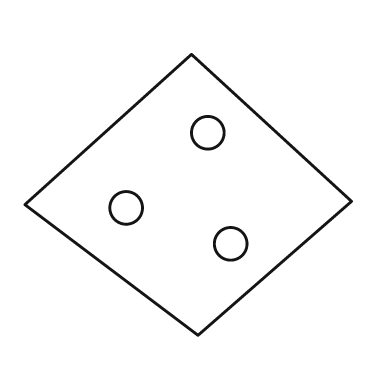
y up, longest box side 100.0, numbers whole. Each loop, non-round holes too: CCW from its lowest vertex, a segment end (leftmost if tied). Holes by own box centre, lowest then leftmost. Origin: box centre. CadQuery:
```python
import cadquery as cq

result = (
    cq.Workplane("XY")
    .moveTo(3.0, -43.0)
    .lineTo(50.0, -2.0)
    .lineTo(1.0, 43.0)
    .lineTo(-50.0, -3.0)
    .close()
    .moveTo(13.0, -15.0)
    .circle(5.0)
    .moveTo(-19.0, -4.0)
    .circle(5.0)
    .moveTo(6.0, 19.0)
    .circle(5.0)
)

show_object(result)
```